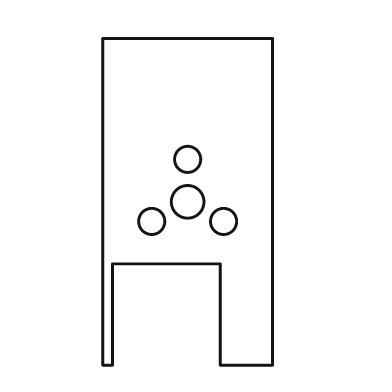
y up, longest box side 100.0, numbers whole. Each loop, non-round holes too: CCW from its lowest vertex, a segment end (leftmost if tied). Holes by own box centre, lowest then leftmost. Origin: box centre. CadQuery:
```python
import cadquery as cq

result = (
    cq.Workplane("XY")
    .moveTo(-26.0, -50.0)
    .lineTo(-23.0, -50.0)
    .lineTo(-23.0, -19.0)
    .lineTo(10.0, -19.0)
    .lineTo(10.0, -50.0)
    .lineTo(26.0, -50.0)
    .lineTo(26.0, 50.0)
    .lineTo(-26.0, 50.0)
    .close()
    .moveTo(-11.0, -6.0)
    .circle(4.0)
    .moveTo(11.0, -6.0)
    .circle(4.0)
    .moveTo(0.0, 0.0)
    .circle(5.0)
    .moveTo(0.0, 13.0)
    .circle(4.0)
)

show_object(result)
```